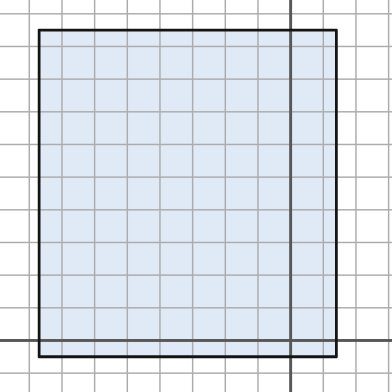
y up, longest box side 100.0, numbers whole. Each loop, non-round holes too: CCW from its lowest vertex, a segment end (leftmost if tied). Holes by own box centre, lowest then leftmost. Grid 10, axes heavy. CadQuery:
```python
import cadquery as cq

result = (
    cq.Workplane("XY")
    .moveTo(-77.0, -5.0)
    .lineTo(14.0, -5.0)
    .lineTo(14.0, 95.0)
    .lineTo(-77.0, 95.0)
    .close()
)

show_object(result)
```